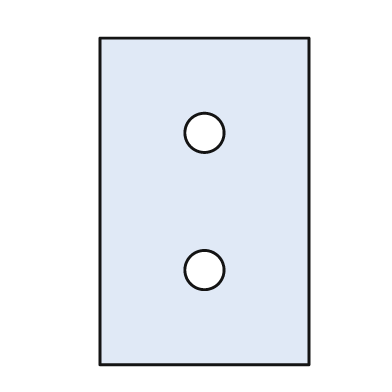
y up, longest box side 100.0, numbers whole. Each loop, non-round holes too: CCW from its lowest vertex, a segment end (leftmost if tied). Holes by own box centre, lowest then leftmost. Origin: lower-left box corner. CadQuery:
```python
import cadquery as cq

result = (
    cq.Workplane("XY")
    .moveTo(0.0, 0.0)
    .lineTo(64.0, 0.0)
    .lineTo(64.0, 100.0)
    .lineTo(0.0, 100.0)
    .close()
    .moveTo(32.0, 29.0)
    .circle(6.0)
    .moveTo(32.0, 71.0)
    .circle(6.0)
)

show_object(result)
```